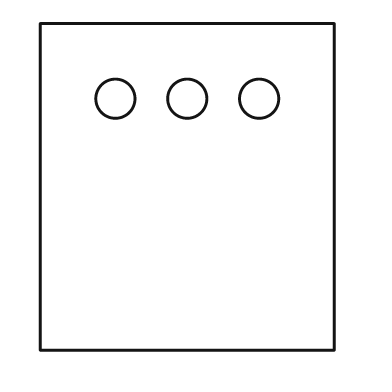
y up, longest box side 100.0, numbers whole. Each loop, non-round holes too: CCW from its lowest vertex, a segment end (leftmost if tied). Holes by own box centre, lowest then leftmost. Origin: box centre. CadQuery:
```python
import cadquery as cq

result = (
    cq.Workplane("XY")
    .moveTo(-45.0, -50.0)
    .lineTo(45.0, -50.0)
    .lineTo(45.0, 50.0)
    .lineTo(-45.0, 50.0)
    .close()
    .moveTo(-22.0, 27.0)
    .circle(6.0)
    .moveTo(0.0, 27.0)
    .circle(6.0)
    .moveTo(22.0, 27.0)
    .circle(6.0)
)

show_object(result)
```